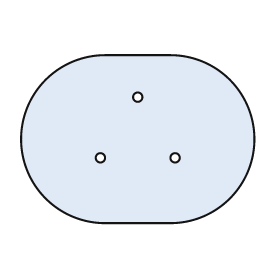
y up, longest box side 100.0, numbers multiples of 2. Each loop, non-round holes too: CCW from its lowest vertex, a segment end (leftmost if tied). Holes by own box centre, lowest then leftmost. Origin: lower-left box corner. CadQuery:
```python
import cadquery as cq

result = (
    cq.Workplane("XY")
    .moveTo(36.0, 0.0)
    .lineTo(64.0, 0.0)
    .threePointArc((100.0, 36.0), (64.0, 72.0))
    .lineTo(36.0, 72.0)
    .threePointArc((0.0, 36.0), (36.0, 0.0))
    .close()
    .moveTo(34.0, 28.0)
    .circle(2.0)
    .moveTo(66.0, 28.0)
    .circle(2.0)
    .moveTo(50.0, 54.0)
    .circle(2.0)
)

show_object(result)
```